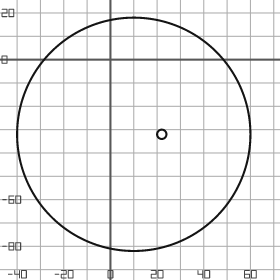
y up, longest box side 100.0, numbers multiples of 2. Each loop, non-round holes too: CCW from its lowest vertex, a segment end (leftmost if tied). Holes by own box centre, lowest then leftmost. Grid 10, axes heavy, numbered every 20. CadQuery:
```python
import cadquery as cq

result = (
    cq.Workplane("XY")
    .moveTo(10.0, -32.0)
    .circle(50.0)
    .moveTo(22.0, -32.0)
    .circle(2.0)
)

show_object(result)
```